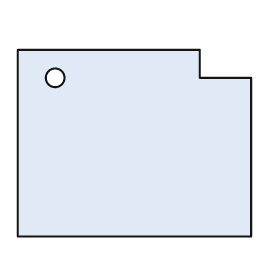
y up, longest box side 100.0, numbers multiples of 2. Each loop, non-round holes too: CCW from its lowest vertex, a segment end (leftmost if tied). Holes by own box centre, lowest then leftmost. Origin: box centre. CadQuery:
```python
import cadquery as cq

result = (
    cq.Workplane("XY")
    .moveTo(-50.0, -40.0)
    .lineTo(50.0, -40.0)
    .lineTo(50.0, 28.0)
    .lineTo(28.0, 28.0)
    .lineTo(28.0, 40.0)
    .lineTo(-50.0, 40.0)
    .close()
    .moveTo(-34.0, 28.0)
    .circle(4.0)
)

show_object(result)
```